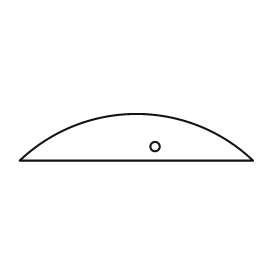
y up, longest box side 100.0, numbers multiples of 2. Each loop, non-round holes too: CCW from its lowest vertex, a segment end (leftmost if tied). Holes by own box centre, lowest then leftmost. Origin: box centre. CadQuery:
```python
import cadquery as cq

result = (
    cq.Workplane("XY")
    .moveTo(-50.0, -10.0)
    .lineTo(50.0, -10.0)
    .threePointArc((0.0, 10.0), (-50.0, -10.0))
    .close()
    .moveTo(8.0, -4.0)
    .circle(2.0)
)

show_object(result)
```